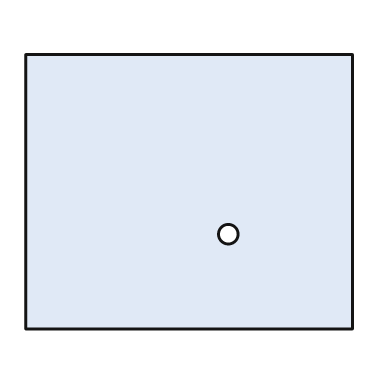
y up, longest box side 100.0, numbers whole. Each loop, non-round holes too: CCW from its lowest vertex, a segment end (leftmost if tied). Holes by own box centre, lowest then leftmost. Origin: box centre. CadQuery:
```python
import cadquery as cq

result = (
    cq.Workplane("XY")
    .moveTo(-50.0, -42.0)
    .lineTo(50.0, -42.0)
    .lineTo(50.0, 42.0)
    .lineTo(-50.0, 42.0)
    .close()
    .moveTo(12.0, -13.0)
    .circle(3.0)
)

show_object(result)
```